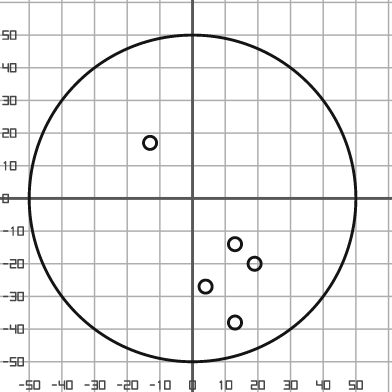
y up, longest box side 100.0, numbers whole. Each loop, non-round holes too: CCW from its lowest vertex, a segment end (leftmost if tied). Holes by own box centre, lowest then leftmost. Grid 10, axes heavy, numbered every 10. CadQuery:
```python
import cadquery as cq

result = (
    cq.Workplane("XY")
    .moveTo(0.0, 0.0)
    .circle(50.0)
    .moveTo(13.0, -38.0)
    .circle(2.0)
    .moveTo(4.0, -27.0)
    .circle(2.0)
    .moveTo(19.0, -20.0)
    .circle(2.0)
    .moveTo(13.0, -14.0)
    .circle(2.0)
    .moveTo(-13.0, 17.0)
    .circle(2.0)
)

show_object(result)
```